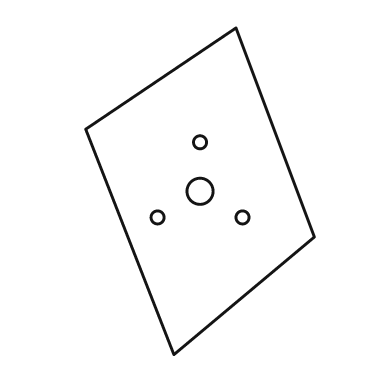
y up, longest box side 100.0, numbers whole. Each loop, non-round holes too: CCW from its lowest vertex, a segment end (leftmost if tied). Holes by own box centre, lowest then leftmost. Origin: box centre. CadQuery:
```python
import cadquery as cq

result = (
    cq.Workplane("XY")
    .moveTo(-8.0, -50.0)
    .lineTo(35.0, -14.0)
    .lineTo(11.0, 50.0)
    .lineTo(-35.0, 19.0)
    .close()
    .moveTo(-13.0, -8.0)
    .circle(2.0)
    .moveTo(13.0, -8.0)
    .circle(2.0)
    .moveTo(0.0, 0.0)
    .circle(4.0)
    .moveTo(0.0, 15.0)
    .circle(2.0)
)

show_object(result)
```